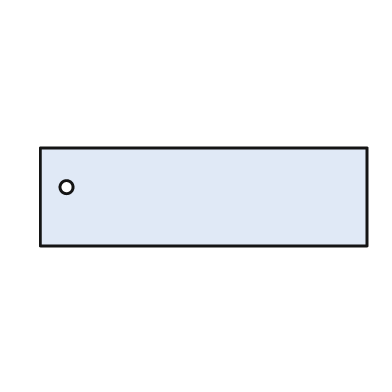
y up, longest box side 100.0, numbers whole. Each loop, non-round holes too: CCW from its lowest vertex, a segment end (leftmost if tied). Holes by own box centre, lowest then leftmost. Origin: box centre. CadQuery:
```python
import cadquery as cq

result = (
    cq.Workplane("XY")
    .moveTo(-50.0, -15.0)
    .lineTo(50.0, -15.0)
    .lineTo(50.0, 15.0)
    .lineTo(-50.0, 15.0)
    .close()
    .moveTo(-42.0, 3.0)
    .circle(2.0)
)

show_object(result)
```